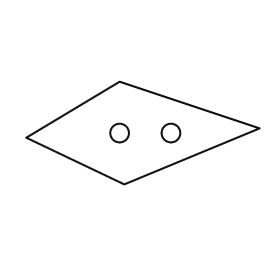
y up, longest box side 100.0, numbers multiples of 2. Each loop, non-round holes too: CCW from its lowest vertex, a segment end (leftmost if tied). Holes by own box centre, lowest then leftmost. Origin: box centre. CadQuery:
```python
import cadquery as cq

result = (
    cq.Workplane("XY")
    .moveTo(-8.0, -22.0)
    .lineTo(50.0, 2.0)
    .lineTo(-10.0, 22.0)
    .lineTo(-50.0, -2.0)
    .close()
    .moveTo(-10.0, 0.0)
    .circle(4.0)
    .moveTo(12.0, 0.0)
    .circle(4.0)
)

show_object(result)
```